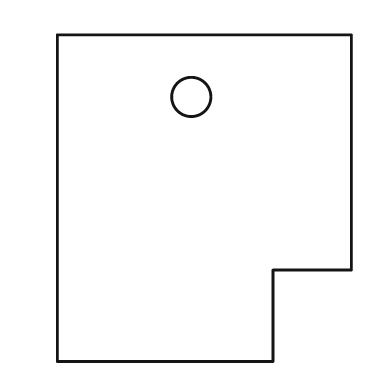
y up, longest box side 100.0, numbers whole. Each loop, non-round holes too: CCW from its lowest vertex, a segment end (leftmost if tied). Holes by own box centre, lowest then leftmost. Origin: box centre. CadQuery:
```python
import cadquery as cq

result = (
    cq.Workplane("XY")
    .moveTo(-45.0, -50.0)
    .lineTo(21.0, -50.0)
    .lineTo(21.0, -22.0)
    .lineTo(45.0, -22.0)
    .lineTo(45.0, 50.0)
    .lineTo(-45.0, 50.0)
    .close()
    .moveTo(-4.0, 31.0)
    .circle(6.0)
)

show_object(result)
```